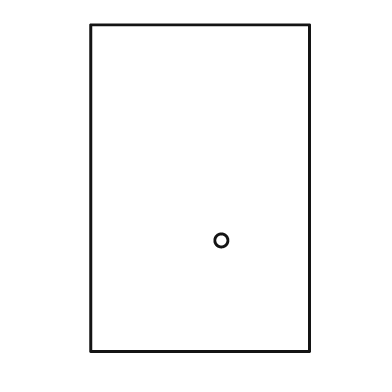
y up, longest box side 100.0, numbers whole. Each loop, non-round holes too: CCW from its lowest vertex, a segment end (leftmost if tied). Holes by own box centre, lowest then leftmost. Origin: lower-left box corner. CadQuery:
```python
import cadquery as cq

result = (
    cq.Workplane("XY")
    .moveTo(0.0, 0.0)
    .lineTo(67.0, 0.0)
    .lineTo(67.0, 100.0)
    .lineTo(0.0, 100.0)
    .close()
    .moveTo(40.0, 34.0)
    .circle(2.0)
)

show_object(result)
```